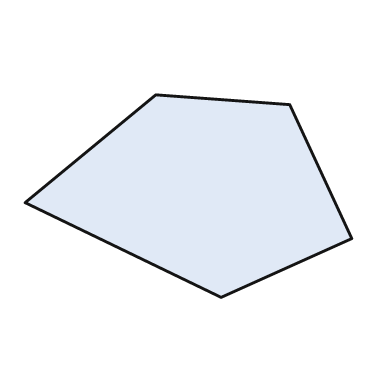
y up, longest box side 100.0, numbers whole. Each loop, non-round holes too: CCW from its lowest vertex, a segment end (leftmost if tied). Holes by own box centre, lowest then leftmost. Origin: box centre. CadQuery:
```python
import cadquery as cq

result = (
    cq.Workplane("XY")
    .moveTo(10.0, -31.0)
    .lineTo(50.0, -13.0)
    .lineTo(31.0, 28.0)
    .lineTo(-10.0, 31.0)
    .lineTo(-50.0, -2.0)
    .close()
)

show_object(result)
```